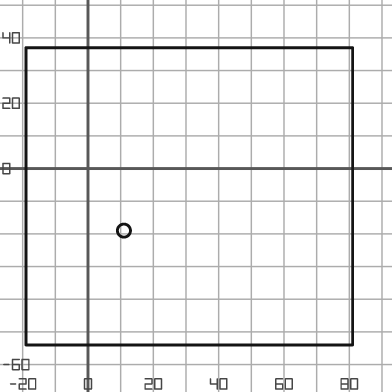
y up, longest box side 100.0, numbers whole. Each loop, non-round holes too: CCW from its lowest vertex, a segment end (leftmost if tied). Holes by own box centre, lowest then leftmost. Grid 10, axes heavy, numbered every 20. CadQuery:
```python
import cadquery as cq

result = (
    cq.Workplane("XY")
    .moveTo(-19.0, -54.0)
    .lineTo(81.0, -54.0)
    .lineTo(81.0, 37.0)
    .lineTo(-19.0, 37.0)
    .close()
    .moveTo(11.0, -19.0)
    .circle(2.0)
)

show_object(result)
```